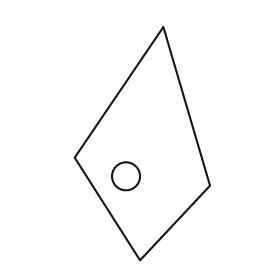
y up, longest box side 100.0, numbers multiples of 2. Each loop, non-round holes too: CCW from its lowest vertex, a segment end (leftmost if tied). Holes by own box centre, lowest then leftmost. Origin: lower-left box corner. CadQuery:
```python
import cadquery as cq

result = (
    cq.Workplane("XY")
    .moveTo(28.0, 0.0)
    .lineTo(58.0, 32.0)
    .lineTo(38.0, 100.0)
    .lineTo(0.0, 44.0)
    .close()
    .moveTo(22.0, 36.0)
    .circle(6.0)
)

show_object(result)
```